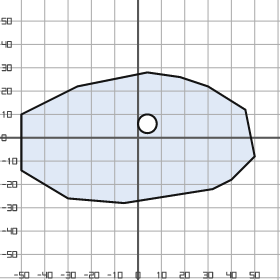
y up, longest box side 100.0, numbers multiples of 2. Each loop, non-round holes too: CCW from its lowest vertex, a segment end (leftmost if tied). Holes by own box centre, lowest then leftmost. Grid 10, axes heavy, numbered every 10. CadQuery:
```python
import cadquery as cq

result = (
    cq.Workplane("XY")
    .moveTo(-6.0, -28.0)
    .lineTo(32.0, -22.0)
    .lineTo(40.0, -18.0)
    .lineTo(50.0, -8.0)
    .lineTo(46.0, 12.0)
    .lineTo(30.0, 22.0)
    .lineTo(18.0, 26.0)
    .lineTo(4.0, 28.0)
    .lineTo(-26.0, 22.0)
    .lineTo(-50.0, 10.0)
    .lineTo(-50.0, -14.0)
    .lineTo(-30.0, -26.0)
    .close()
    .moveTo(4.0, 6.0)
    .circle(4.0)
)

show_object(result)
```